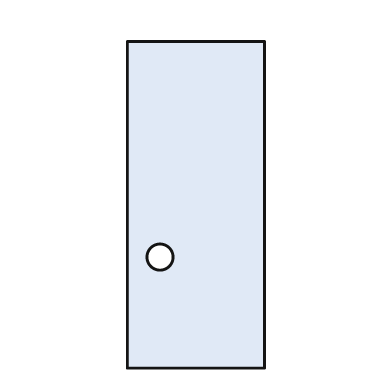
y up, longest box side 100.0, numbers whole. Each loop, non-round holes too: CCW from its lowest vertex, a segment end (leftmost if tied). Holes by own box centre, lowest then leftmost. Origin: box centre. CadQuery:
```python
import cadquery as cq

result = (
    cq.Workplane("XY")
    .moveTo(-21.0, -50.0)
    .lineTo(21.0, -50.0)
    .lineTo(21.0, 50.0)
    .lineTo(-21.0, 50.0)
    .close()
    .moveTo(-11.0, -16.0)
    .circle(4.0)
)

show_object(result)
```